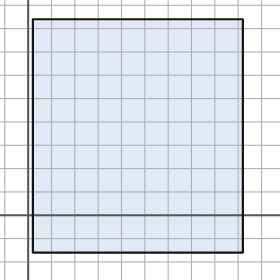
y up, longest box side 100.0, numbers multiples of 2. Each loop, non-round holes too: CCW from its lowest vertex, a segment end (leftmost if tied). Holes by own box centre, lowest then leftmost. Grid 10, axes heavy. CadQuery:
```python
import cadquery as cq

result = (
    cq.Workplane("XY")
    .moveTo(2.0, -16.0)
    .lineTo(92.0, -16.0)
    .lineTo(92.0, 84.0)
    .lineTo(2.0, 84.0)
    .close()
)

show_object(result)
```